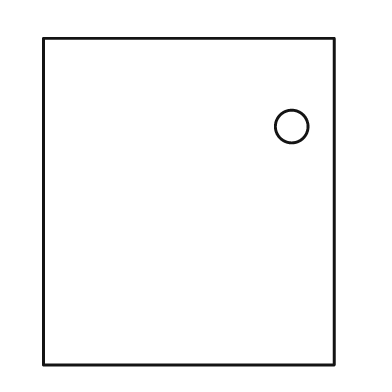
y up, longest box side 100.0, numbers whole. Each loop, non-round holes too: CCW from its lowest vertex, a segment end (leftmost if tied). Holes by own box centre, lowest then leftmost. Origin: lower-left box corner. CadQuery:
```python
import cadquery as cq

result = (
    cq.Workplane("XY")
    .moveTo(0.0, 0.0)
    .lineTo(89.0, 0.0)
    .lineTo(89.0, 100.0)
    .lineTo(0.0, 100.0)
    .close()
    .moveTo(76.0, 73.0)
    .circle(5.0)
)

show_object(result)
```